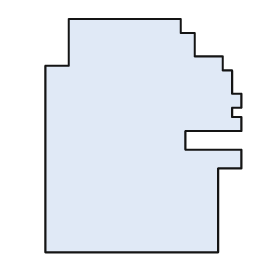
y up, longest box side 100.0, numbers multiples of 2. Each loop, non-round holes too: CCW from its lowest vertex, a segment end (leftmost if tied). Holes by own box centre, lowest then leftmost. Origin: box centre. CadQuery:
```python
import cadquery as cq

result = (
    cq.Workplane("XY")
    .moveTo(-42.0, -50.0)
    .lineTo(32.0, -50.0)
    .lineTo(32.0, -14.0)
    .lineTo(42.0, -14.0)
    .lineTo(42.0, -6.0)
    .lineTo(18.0, -6.0)
    .lineTo(18.0, 2.0)
    .lineTo(42.0, 2.0)
    .lineTo(42.0, 8.0)
    .lineTo(38.0, 8.0)
    .lineTo(38.0, 12.0)
    .lineTo(42.0, 12.0)
    .lineTo(42.0, 18.0)
    .lineTo(38.0, 18.0)
    .lineTo(38.0, 28.0)
    .lineTo(34.0, 28.0)
    .lineTo(34.0, 34.0)
    .lineTo(22.0, 34.0)
    .lineTo(22.0, 44.0)
    .lineTo(16.0, 44.0)
    .lineTo(16.0, 50.0)
    .lineTo(-32.0, 50.0)
    .lineTo(-32.0, 30.0)
    .lineTo(-42.0, 30.0)
    .close()
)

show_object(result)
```